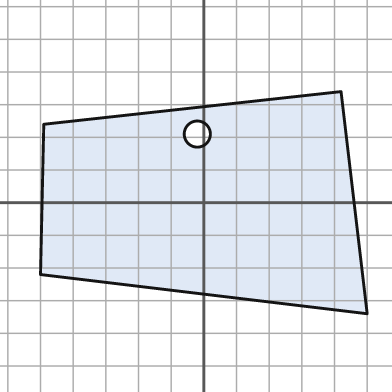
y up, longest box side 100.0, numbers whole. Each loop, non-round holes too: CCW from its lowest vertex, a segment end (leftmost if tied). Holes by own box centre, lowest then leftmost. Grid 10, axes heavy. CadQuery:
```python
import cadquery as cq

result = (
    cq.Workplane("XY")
    .moveTo(50.0, -34.0)
    .lineTo(42.0, 34.0)
    .lineTo(-49.0, 24.0)
    .lineTo(-50.0, -22.0)
    .close()
    .moveTo(-2.0, 21.0)
    .circle(4.0)
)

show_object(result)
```